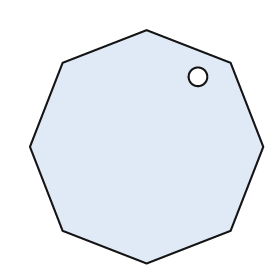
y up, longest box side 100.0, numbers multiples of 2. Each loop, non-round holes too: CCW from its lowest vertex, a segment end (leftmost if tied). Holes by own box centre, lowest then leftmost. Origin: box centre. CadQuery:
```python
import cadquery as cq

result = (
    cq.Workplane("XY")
    .moveTo(0.0, -50.0)
    .lineTo(36.0, -36.0)
    .lineTo(50.0, 0.0)
    .lineTo(36.0, 36.0)
    .lineTo(0.0, 50.0)
    .lineTo(-36.0, 36.0)
    .lineTo(-50.0, 0.0)
    .lineTo(-36.0, -36.0)
    .close()
    .moveTo(22.0, 30.0)
    .circle(4.0)
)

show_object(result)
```